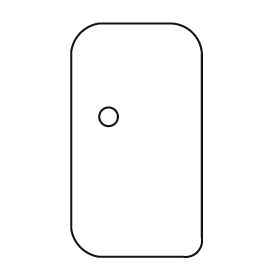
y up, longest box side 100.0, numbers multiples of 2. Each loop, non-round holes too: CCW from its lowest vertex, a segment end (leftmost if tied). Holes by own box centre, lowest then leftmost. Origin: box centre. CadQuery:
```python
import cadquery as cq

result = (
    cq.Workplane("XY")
    .moveTo(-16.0, -50.0)
    .lineTo(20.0, -50.0)
    .threePointArc((26.0, -48.0), (28.0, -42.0))
    .lineTo(28.0, 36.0)
    .threePointArc((24.0, 46.0), (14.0, 50.0))
    .lineTo(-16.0, 50.0)
    .threePointArc((-24.0, 46.0), (-28.0, 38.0))
    .lineTo(-28.0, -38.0)
    .threePointArc((-24.0, -46.0), (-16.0, -50.0))
    .close()
    .moveTo(-12.0, 10.0)
    .circle(4.0)
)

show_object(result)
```